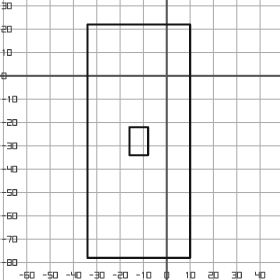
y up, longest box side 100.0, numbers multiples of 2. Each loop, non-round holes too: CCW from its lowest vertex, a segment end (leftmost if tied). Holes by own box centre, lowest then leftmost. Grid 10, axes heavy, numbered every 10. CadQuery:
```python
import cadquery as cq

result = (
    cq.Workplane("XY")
    .moveTo(-34.0, -78.0)
    .lineTo(10.0, -78.0)
    .lineTo(10.0, 22.0)
    .lineTo(-34.0, 22.0)
    .close()
    .moveTo(-16.0, -34.0)
    .lineTo(-8.0, -34.0)
    .lineTo(-8.0, -22.0)
    .lineTo(-16.0, -22.0)
    .close()
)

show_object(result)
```